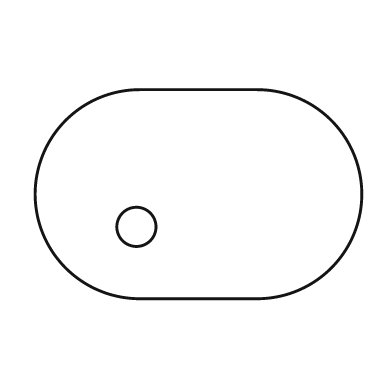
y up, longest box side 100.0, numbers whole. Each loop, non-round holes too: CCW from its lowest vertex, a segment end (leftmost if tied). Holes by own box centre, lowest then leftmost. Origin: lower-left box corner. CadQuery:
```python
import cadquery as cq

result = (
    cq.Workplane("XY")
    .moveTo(32.0, 0.0)
    .lineTo(68.0, 0.0)
    .threePointArc((100.0, 32.0), (68.0, 64.0))
    .lineTo(32.0, 64.0)
    .threePointArc((0.0, 32.0), (32.0, 0.0))
    .close()
    .moveTo(31.0, 22.0)
    .circle(6.0)
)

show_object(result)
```